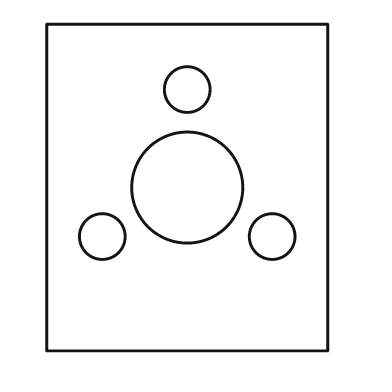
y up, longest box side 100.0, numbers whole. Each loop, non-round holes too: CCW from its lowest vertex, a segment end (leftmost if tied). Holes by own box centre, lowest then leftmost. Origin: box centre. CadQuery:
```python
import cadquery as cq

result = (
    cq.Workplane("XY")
    .moveTo(-43.0, -50.0)
    .lineTo(43.0, -50.0)
    .lineTo(43.0, 50.0)
    .lineTo(-43.0, 50.0)
    .close()
    .moveTo(-26.0, -15.0)
    .circle(7.0)
    .moveTo(26.0, -15.0)
    .circle(7.0)
    .moveTo(0.0, 0.0)
    .circle(17.0)
    .moveTo(0.0, 30.0)
    .circle(7.0)
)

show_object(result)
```